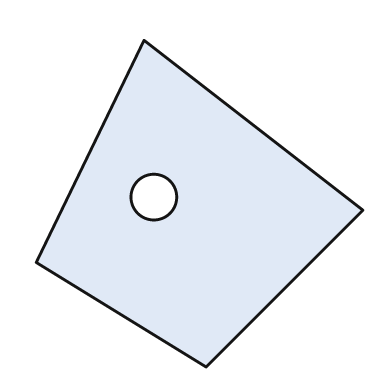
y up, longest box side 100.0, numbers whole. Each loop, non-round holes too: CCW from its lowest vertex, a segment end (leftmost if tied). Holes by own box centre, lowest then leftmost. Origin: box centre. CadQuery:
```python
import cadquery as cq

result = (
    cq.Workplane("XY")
    .moveTo(2.0, -50.0)
    .lineTo(50.0, -2.0)
    .lineTo(-17.0, 50.0)
    .lineTo(-50.0, -18.0)
    .close()
    .moveTo(-14.0, 2.0)
    .circle(7.0)
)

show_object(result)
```